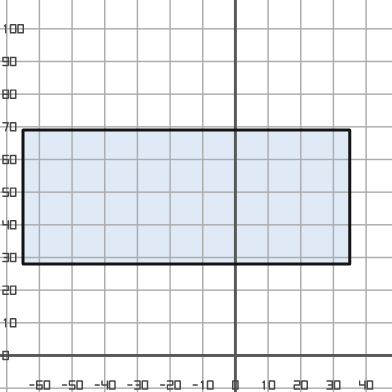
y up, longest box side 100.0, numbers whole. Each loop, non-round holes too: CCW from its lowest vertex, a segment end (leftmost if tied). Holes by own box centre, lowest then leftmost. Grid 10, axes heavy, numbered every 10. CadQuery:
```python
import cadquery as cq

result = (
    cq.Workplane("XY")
    .moveTo(-65.0, 28.0)
    .lineTo(35.0, 28.0)
    .lineTo(35.0, 69.0)
    .lineTo(-65.0, 69.0)
    .close()
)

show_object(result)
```